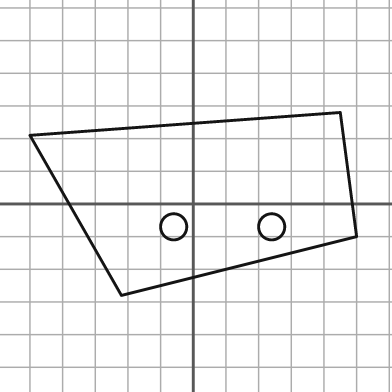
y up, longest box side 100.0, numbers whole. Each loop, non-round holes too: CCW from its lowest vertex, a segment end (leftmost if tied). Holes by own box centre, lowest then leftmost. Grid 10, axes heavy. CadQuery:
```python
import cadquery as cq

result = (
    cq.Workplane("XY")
    .moveTo(-22.0, -28.0)
    .lineTo(50.0, -10.0)
    .lineTo(45.0, 28.0)
    .lineTo(-50.0, 21.0)
    .close()
    .moveTo(-6.0, -7.0)
    .circle(4.0)
    .moveTo(24.0, -7.0)
    .circle(4.0)
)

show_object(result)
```